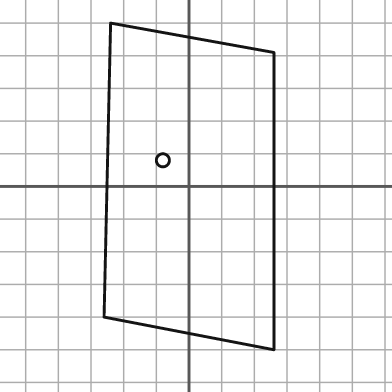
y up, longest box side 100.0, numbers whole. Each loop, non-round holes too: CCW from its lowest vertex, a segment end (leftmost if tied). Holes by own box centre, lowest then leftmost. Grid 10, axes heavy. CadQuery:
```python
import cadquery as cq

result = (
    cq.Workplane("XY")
    .moveTo(26.0, -50.0)
    .lineTo(26.0, 41.0)
    .lineTo(-24.0, 50.0)
    .lineTo(-26.0, -40.0)
    .close()
    .moveTo(-8.0, 8.0)
    .circle(2.0)
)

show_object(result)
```